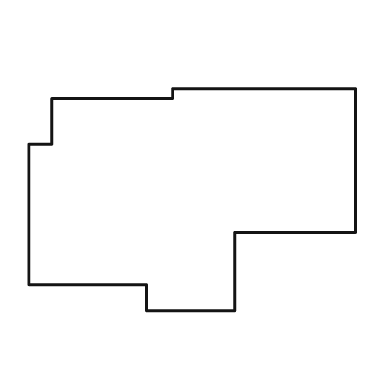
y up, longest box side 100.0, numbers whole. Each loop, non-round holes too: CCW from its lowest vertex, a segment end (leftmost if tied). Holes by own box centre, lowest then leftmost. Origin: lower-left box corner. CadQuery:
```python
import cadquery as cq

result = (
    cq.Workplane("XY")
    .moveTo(36.0, 0.0)
    .lineTo(63.0, 0.0)
    .lineTo(63.0, 24.0)
    .lineTo(100.0, 24.0)
    .lineTo(100.0, 68.0)
    .lineTo(44.0, 68.0)
    .lineTo(44.0, 65.0)
    .lineTo(7.0, 65.0)
    .lineTo(7.0, 51.0)
    .lineTo(0.0, 51.0)
    .lineTo(0.0, 8.0)
    .lineTo(36.0, 8.0)
    .close()
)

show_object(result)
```